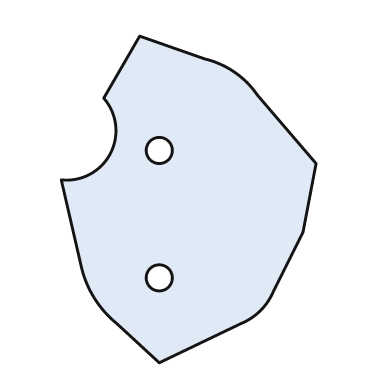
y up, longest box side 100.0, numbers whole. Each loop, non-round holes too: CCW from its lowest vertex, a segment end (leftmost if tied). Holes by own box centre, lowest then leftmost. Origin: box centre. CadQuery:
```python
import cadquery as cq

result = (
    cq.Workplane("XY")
    .moveTo(-9.0, -50.0)
    .lineTo(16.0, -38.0)
    .threePointArc((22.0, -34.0), (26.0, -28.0))
    .lineTo(35.0, -10.0)
    .lineTo(39.0, 11.0)
    .lineTo(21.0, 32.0)
    .threePointArc((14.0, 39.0), (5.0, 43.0))
    .lineTo(-15.0, 50.0)
    .lineTo(-26.0, 31.0)
    .threePointArc((-24.0, 14.0), (-39.0, 6.0))
    .lineTo(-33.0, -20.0)
    .threePointArc((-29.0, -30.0), (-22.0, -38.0))
    .close()
    .moveTo(-9.0, -24.0)
    .circle(4.0)
    .moveTo(-9.0, 15.0)
    .circle(4.0)
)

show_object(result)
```